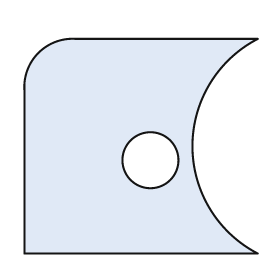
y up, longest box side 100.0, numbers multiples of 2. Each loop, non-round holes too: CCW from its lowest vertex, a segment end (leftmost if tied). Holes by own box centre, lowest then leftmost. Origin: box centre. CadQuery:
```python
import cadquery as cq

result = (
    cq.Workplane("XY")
    .moveTo(-50.0, -46.0)
    .lineTo(50.0, -46.0)
    .threePointArc((22.0, 0.0), (50.0, 46.0))
    .lineTo(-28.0, 46.0)
    .threePointArc((-44.0, 40.0), (-50.0, 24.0))
    .close()
    .moveTo(4.0, -6.0)
    .circle(12.0)
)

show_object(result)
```